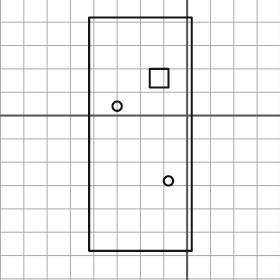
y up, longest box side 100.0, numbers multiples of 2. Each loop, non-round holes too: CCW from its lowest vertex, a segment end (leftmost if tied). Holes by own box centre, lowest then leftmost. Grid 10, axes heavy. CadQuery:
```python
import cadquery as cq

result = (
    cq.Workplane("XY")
    .moveTo(-42.0, -58.0)
    .lineTo(2.0, -58.0)
    .lineTo(2.0, 42.0)
    .lineTo(-42.0, 42.0)
    .close()
    .moveTo(-8.0, -28.0)
    .circle(2.0)
    .moveTo(-30.0, 4.0)
    .circle(2.0)
    .moveTo(-16.0, 12.0)
    .lineTo(-8.0, 12.0)
    .lineTo(-8.0, 20.0)
    .lineTo(-16.0, 20.0)
    .close()
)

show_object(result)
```